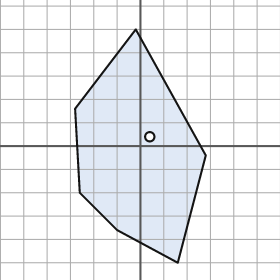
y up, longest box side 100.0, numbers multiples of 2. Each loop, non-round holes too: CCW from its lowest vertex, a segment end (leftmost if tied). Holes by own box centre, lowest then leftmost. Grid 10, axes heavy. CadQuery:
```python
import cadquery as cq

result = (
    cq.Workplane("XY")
    .moveTo(16.0, -50.0)
    .lineTo(28.0, -4.0)
    .lineTo(-2.0, 50.0)
    .lineTo(-28.0, 16.0)
    .lineTo(-26.0, -20.0)
    .lineTo(-10.0, -36.0)
    .close()
    .moveTo(4.0, 4.0)
    .circle(2.0)
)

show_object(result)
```